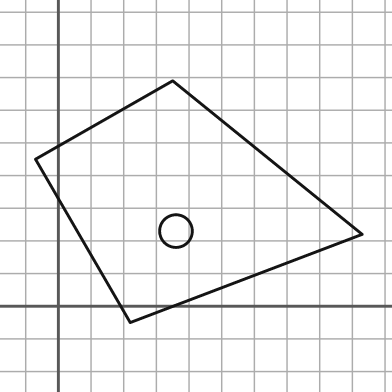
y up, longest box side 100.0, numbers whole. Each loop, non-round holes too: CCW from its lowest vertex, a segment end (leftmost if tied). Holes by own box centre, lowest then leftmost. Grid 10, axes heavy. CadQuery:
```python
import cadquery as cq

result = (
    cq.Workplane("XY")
    .moveTo(22.0, -5.0)
    .lineTo(93.0, 22.0)
    .lineTo(35.0, 69.0)
    .lineTo(-7.0, 45.0)
    .close()
    .moveTo(36.0, 23.0)
    .circle(5.0)
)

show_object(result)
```